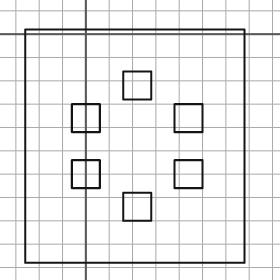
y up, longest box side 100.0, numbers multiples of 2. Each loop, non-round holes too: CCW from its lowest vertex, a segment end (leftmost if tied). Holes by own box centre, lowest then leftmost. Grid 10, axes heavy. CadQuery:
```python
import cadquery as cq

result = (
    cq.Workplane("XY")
    .moveTo(-26.0, -98.0)
    .lineTo(68.0, -98.0)
    .lineTo(68.0, 2.0)
    .lineTo(-26.0, 2.0)
    .close()
    .moveTo(16.0, -80.0)
    .lineTo(28.0, -80.0)
    .lineTo(28.0, -68.0)
    .lineTo(16.0, -68.0)
    .close()
    .moveTo(-6.0, -66.0)
    .lineTo(6.0, -66.0)
    .lineTo(6.0, -54.0)
    .lineTo(-6.0, -54.0)
    .close()
    .moveTo(38.0, -66.0)
    .lineTo(50.0, -66.0)
    .lineTo(50.0, -54.0)
    .lineTo(38.0, -54.0)
    .close()
    .moveTo(-6.0, -42.0)
    .lineTo(6.0, -42.0)
    .lineTo(6.0, -30.0)
    .lineTo(-6.0, -30.0)
    .close()
    .moveTo(38.0, -42.0)
    .lineTo(50.0, -42.0)
    .lineTo(50.0, -30.0)
    .lineTo(38.0, -30.0)
    .close()
    .moveTo(16.0, -28.0)
    .lineTo(28.0, -28.0)
    .lineTo(28.0, -16.0)
    .lineTo(16.0, -16.0)
    .close()
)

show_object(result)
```